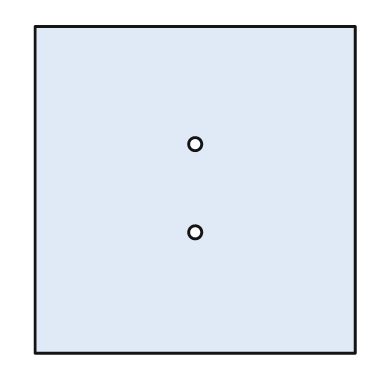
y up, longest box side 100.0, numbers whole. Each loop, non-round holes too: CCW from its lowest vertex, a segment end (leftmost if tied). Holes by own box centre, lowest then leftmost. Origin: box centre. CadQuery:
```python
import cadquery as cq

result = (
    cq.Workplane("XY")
    .moveTo(-49.0, -50.0)
    .lineTo(49.0, -50.0)
    .lineTo(49.0, 50.0)
    .lineTo(-49.0, 50.0)
    .close()
    .moveTo(0.0, -13.0)
    .circle(2.0)
    .moveTo(0.0, 14.0)
    .circle(2.0)
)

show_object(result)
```